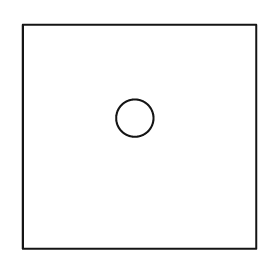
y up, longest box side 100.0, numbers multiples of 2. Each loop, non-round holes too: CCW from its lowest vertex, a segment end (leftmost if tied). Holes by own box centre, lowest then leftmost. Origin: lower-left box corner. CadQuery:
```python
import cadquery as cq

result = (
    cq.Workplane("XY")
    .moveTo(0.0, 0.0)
    .lineTo(100.0, 0.0)
    .lineTo(100.0, 96.0)
    .lineTo(0.0, 96.0)
    .close()
    .moveTo(48.0, 56.0)
    .circle(8.0)
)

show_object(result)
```